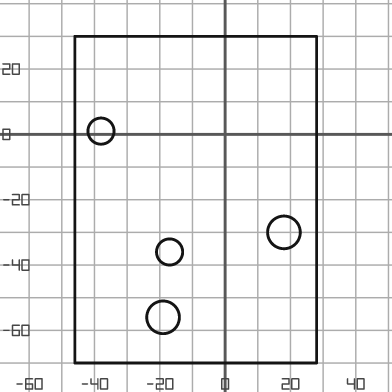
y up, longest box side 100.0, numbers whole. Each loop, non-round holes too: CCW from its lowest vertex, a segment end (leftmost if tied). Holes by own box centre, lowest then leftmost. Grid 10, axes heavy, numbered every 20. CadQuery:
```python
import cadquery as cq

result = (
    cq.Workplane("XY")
    .moveTo(-46.0, -70.0)
    .lineTo(28.0, -70.0)
    .lineTo(28.0, 30.0)
    .lineTo(-46.0, 30.0)
    .close()
    .moveTo(-19.0, -56.0)
    .circle(5.0)
    .moveTo(-17.0, -36.0)
    .circle(4.0)
    .moveTo(18.0, -30.0)
    .circle(5.0)
    .moveTo(-38.0, 1.0)
    .circle(4.0)
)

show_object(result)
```